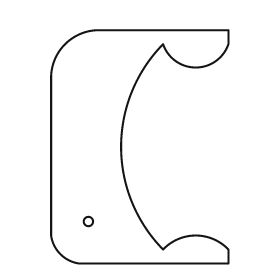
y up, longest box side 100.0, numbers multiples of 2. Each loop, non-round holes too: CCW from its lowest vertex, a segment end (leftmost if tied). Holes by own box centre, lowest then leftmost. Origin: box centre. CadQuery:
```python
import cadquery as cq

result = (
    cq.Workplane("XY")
    .moveTo(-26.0, -50.0)
    .lineTo(38.0, -50.0)
    .lineTo(38.0, -44.0)
    .threePointArc((24.0, -38.0), (10.0, -44.0))
    .threePointArc((-8.0, 0.0), (10.0, 44.0))
    .threePointArc((24.0, 34.0), (38.0, 44.0))
    .lineTo(38.0, 50.0)
    .lineTo(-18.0, 50.0)
    .threePointArc((-32.0, 44.0), (-38.0, 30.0))
    .lineTo(-38.0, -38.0)
    .threePointArc((-34.0, -46.0), (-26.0, -50.0))
    .close()
    .moveTo(-22.0, -32.0)
    .circle(2.0)
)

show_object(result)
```